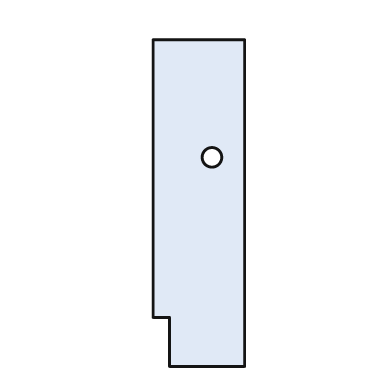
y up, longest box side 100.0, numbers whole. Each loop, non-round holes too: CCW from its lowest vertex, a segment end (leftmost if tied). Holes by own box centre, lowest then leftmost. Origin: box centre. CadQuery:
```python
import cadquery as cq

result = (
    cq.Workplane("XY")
    .moveTo(-9.0, -50.0)
    .lineTo(14.0, -50.0)
    .lineTo(14.0, 50.0)
    .lineTo(-14.0, 50.0)
    .lineTo(-14.0, -35.0)
    .lineTo(-9.0, -35.0)
    .close()
    .moveTo(4.0, 14.0)
    .circle(3.0)
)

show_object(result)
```